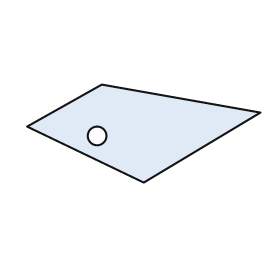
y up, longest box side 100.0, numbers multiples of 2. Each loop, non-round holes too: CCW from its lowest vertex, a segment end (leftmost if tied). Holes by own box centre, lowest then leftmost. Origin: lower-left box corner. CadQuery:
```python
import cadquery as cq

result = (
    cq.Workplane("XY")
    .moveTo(50.0, 0.0)
    .lineTo(100.0, 30.0)
    .lineTo(32.0, 42.0)
    .lineTo(0.0, 24.0)
    .close()
    .moveTo(30.0, 20.0)
    .circle(4.0)
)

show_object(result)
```